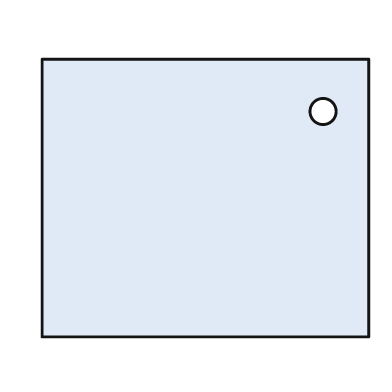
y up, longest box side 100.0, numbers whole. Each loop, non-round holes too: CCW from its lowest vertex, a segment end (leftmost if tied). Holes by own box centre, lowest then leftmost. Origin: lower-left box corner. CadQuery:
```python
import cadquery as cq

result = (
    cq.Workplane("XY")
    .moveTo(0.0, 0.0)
    .lineTo(100.0, 0.0)
    .lineTo(100.0, 85.0)
    .lineTo(0.0, 85.0)
    .close()
    .moveTo(86.0, 69.0)
    .circle(4.0)
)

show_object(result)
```